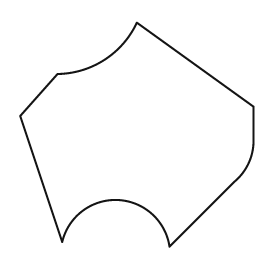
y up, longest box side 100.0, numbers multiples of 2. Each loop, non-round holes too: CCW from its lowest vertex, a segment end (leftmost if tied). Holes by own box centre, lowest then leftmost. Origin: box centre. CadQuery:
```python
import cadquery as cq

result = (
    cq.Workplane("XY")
    .moveTo(14.0, -48.0)
    .lineTo(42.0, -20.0)
    .threePointArc((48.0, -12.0), (50.0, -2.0))
    .lineTo(50.0, 12.0)
    .lineTo(0.0, 48.0)
    .threePointArc((-14.0, 32.0), (-34.0, 26.0))
    .lineTo(-50.0, 8.0)
    .lineTo(-32.0, -46.0)
    .threePointArc((-8.0, -28.0), (14.0, -48.0))
    .close()
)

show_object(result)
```